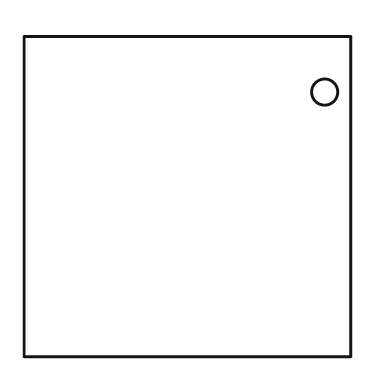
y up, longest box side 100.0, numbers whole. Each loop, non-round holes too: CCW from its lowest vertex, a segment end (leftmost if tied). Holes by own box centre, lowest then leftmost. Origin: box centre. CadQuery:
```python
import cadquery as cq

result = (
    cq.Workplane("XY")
    .moveTo(-50.0, -49.0)
    .lineTo(50.0, -49.0)
    .lineTo(50.0, 49.0)
    .lineTo(-50.0, 49.0)
    .close()
    .moveTo(42.0, 32.0)
    .circle(4.0)
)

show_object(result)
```